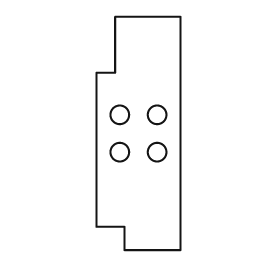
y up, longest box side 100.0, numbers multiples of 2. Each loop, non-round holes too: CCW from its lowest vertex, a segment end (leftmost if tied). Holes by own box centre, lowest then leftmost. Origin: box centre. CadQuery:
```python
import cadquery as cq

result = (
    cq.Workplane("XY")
    .moveTo(-6.0, -50.0)
    .lineTo(18.0, -50.0)
    .lineTo(18.0, 50.0)
    .lineTo(-10.0, 50.0)
    .lineTo(-10.0, 26.0)
    .lineTo(-18.0, 26.0)
    .lineTo(-18.0, -40.0)
    .lineTo(-6.0, -40.0)
    .close()
    .moveTo(-8.0, -8.0)
    .circle(4.0)
    .moveTo(8.0, -8.0)
    .circle(4.0)
    .moveTo(-8.0, 8.0)
    .circle(4.0)
    .moveTo(8.0, 8.0)
    .circle(4.0)
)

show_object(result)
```